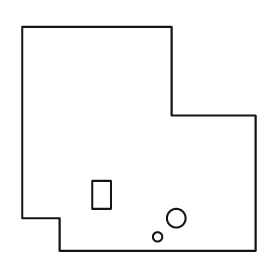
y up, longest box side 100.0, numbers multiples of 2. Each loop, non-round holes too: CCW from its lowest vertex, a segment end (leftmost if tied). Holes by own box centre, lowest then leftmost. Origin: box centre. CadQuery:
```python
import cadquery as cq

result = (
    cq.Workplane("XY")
    .moveTo(-34.0, -48.0)
    .lineTo(50.0, -48.0)
    .lineTo(50.0, 10.0)
    .lineTo(14.0, 10.0)
    .lineTo(14.0, 48.0)
    .lineTo(-50.0, 48.0)
    .lineTo(-50.0, -34.0)
    .lineTo(-34.0, -34.0)
    .close()
    .moveTo(8.0, -42.0)
    .circle(2.0)
    .moveTo(16.0, -34.0)
    .circle(4.0)
    .moveTo(-20.0, -30.0)
    .lineTo(-12.0, -30.0)
    .lineTo(-12.0, -18.0)
    .lineTo(-20.0, -18.0)
    .close()
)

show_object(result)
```